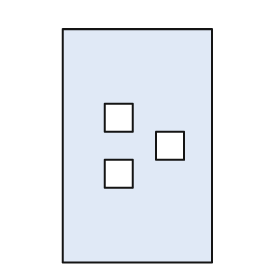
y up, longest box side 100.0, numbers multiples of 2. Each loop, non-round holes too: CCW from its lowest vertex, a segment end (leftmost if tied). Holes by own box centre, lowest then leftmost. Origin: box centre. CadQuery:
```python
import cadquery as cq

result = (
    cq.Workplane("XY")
    .moveTo(-32.0, -50.0)
    .lineTo(32.0, -50.0)
    .lineTo(32.0, 50.0)
    .lineTo(-32.0, 50.0)
    .close()
    .moveTo(-14.0, -18.0)
    .lineTo(-2.0, -18.0)
    .lineTo(-2.0, -6.0)
    .lineTo(-14.0, -6.0)
    .close()
    .moveTo(8.0, -6.0)
    .lineTo(20.0, -6.0)
    .lineTo(20.0, 6.0)
    .lineTo(8.0, 6.0)
    .close()
    .moveTo(-14.0, 6.0)
    .lineTo(-2.0, 6.0)
    .lineTo(-2.0, 18.0)
    .lineTo(-14.0, 18.0)
    .close()
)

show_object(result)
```